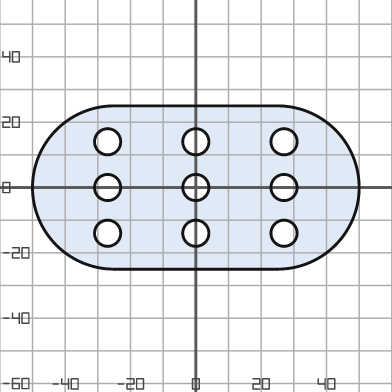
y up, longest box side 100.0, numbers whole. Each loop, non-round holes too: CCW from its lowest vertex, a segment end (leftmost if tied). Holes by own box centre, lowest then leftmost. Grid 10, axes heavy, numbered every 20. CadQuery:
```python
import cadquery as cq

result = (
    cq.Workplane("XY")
    .moveTo(-25.0, -25.0)
    .lineTo(25.0, -25.0)
    .threePointArc((50.0, 0.0), (25.0, 25.0))
    .lineTo(-25.0, 25.0)
    .threePointArc((-50.0, 0.0), (-25.0, -25.0))
    .close()
    .moveTo(-27.0, -14.0)
    .circle(4.0)
    .moveTo(0.0, -14.0)
    .circle(4.0)
    .moveTo(27.0, -14.0)
    .circle(4.0)
    .moveTo(-27.0, 0.0)
    .circle(4.0)
    .moveTo(0.0, 0.0)
    .circle(4.0)
    .moveTo(27.0, 0.0)
    .circle(4.0)
    .moveTo(-27.0, 14.0)
    .circle(4.0)
    .moveTo(0.0, 14.0)
    .circle(4.0)
    .moveTo(27.0, 14.0)
    .circle(4.0)
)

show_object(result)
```